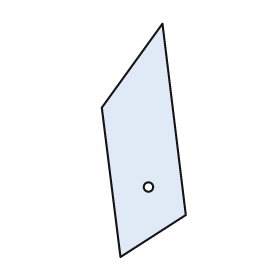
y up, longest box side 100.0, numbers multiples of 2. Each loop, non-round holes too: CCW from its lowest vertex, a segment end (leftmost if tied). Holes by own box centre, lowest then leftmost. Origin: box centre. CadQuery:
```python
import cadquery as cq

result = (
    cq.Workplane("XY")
    .moveTo(-10.0, -50.0)
    .lineTo(18.0, -32.0)
    .lineTo(8.0, 50.0)
    .lineTo(-18.0, 14.0)
    .close()
    .moveTo(2.0, -20.0)
    .circle(2.0)
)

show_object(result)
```